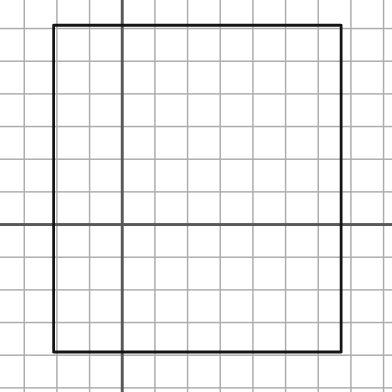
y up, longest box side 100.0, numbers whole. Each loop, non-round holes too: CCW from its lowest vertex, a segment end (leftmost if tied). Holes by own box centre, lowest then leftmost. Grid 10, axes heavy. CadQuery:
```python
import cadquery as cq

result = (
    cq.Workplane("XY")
    .moveTo(-21.0, -39.0)
    .lineTo(67.0, -39.0)
    .lineTo(67.0, 61.0)
    .lineTo(-21.0, 61.0)
    .close()
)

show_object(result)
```